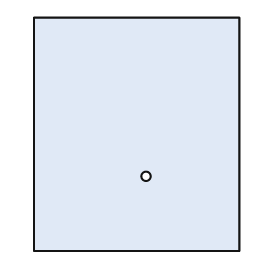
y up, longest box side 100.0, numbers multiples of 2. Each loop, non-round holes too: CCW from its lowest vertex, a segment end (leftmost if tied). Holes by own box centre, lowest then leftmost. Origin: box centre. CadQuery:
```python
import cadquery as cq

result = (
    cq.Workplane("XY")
    .moveTo(-44.0, -50.0)
    .lineTo(44.0, -50.0)
    .lineTo(44.0, 50.0)
    .lineTo(-44.0, 50.0)
    .close()
    .moveTo(4.0, -18.0)
    .circle(2.0)
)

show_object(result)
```